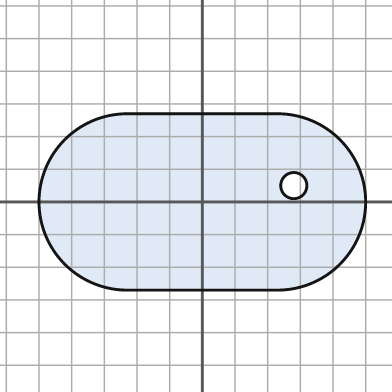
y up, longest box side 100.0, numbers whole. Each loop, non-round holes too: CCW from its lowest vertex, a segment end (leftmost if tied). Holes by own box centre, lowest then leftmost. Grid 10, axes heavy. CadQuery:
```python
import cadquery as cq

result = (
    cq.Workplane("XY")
    .moveTo(-23.0, -27.0)
    .lineTo(23.0, -27.0)
    .threePointArc((50.0, 0.0), (23.0, 27.0))
    .lineTo(-23.0, 27.0)
    .threePointArc((-50.0, 0.0), (-23.0, -27.0))
    .close()
    .moveTo(28.0, 5.0)
    .circle(4.0)
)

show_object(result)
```